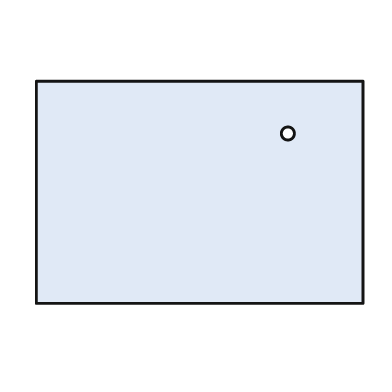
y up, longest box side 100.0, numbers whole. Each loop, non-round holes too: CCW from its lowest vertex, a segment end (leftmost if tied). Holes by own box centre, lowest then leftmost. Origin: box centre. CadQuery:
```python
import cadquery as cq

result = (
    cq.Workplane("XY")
    .moveTo(-50.0, -34.0)
    .lineTo(50.0, -34.0)
    .lineTo(50.0, 34.0)
    .lineTo(-50.0, 34.0)
    .close()
    .moveTo(27.0, 18.0)
    .circle(2.0)
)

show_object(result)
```